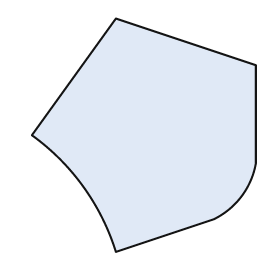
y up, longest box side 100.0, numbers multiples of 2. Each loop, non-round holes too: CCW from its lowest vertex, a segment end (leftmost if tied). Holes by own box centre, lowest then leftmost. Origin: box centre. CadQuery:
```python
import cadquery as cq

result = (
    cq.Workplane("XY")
    .moveTo(-12.0, -50.0)
    .lineTo(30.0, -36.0)
    .threePointArc((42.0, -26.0), (48.0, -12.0))
    .lineTo(48.0, 30.0)
    .lineTo(-12.0, 50.0)
    .lineTo(-48.0, 0.0)
    .threePointArc((-26.0, -22.0), (-12.0, -50.0))
    .close()
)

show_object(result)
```